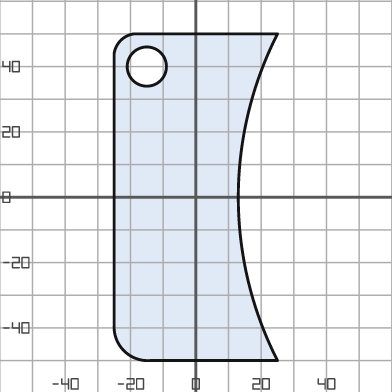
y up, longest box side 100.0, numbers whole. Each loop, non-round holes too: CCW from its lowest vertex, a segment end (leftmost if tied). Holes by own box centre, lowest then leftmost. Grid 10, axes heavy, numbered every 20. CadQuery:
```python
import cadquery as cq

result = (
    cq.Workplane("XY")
    .moveTo(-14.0, -50.0)
    .lineTo(25.0, -50.0)
    .threePointArc((13.0, 0.0), (25.0, 50.0))
    .lineTo(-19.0, 50.0)
    .threePointArc((-23.0, 48.0), (-25.0, 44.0))
    .lineTo(-25.0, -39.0)
    .threePointArc((-22.0, -47.0), (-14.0, -50.0))
    .close()
    .moveTo(-15.0, 40.0)
    .circle(6.0)
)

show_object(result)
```